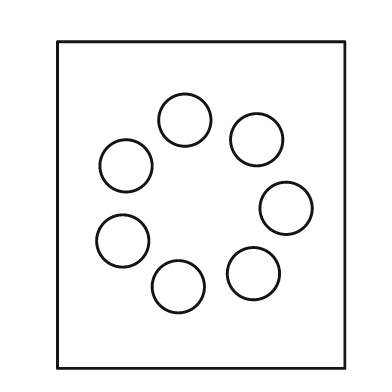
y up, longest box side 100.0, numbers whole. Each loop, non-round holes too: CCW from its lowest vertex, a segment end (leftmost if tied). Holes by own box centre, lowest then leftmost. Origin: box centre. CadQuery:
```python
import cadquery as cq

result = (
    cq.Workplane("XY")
    .moveTo(-44.0, -50.0)
    .lineTo(44.0, -50.0)
    .lineTo(44.0, 50.0)
    .lineTo(-44.0, 50.0)
    .close()
    .moveTo(-7.0, -25.0)
    .circle(8.0)
    .moveTo(16.0, -21.0)
    .circle(8.0)
    .moveTo(-24.0, -11.0)
    .circle(8.0)
    .moveTo(26.0, -1.0)
    .circle(8.0)
    .moveTo(-23.0, 12.0)
    .circle(8.0)
    .moveTo(17.0, 20.0)
    .circle(8.0)
    .moveTo(-5.0, 26.0)
    .circle(8.0)
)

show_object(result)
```